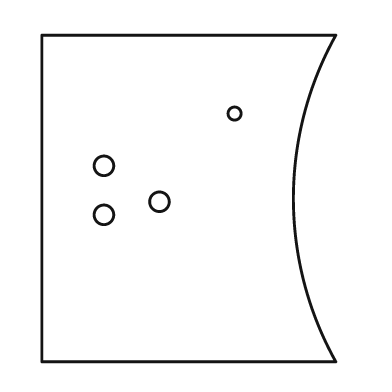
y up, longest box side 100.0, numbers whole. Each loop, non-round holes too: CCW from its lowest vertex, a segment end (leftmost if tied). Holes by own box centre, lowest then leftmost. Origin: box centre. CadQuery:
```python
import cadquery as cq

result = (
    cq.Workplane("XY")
    .moveTo(-45.0, -50.0)
    .lineTo(45.0, -50.0)
    .threePointArc((32.0, 0.0), (45.0, 50.0))
    .lineTo(-45.0, 50.0)
    .close()
    .moveTo(-26.0, -5.0)
    .circle(3.0)
    .moveTo(-9.0, -1.0)
    .circle(3.0)
    .moveTo(-26.0, 10.0)
    .circle(3.0)
    .moveTo(14.0, 26.0)
    .circle(2.0)
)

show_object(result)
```